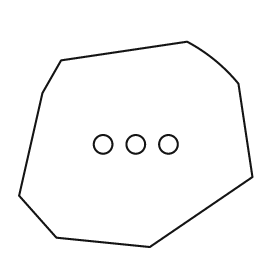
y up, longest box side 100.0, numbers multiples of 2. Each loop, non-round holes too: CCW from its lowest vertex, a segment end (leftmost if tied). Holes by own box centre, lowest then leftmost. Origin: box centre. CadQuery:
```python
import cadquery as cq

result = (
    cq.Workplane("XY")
    .moveTo(6.0, -44.0)
    .lineTo(50.0, -14.0)
    .lineTo(44.0, 26.0)
    .threePointArc((34.0, 36.0), (22.0, 44.0))
    .lineTo(-32.0, 36.0)
    .lineTo(-40.0, 22.0)
    .lineTo(-50.0, -22.0)
    .lineTo(-34.0, -40.0)
    .close()
    .moveTo(-14.0, 0.0)
    .circle(4.0)
    .moveTo(0.0, 0.0)
    .circle(4.0)
    .moveTo(14.0, 0.0)
    .circle(4.0)
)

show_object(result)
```